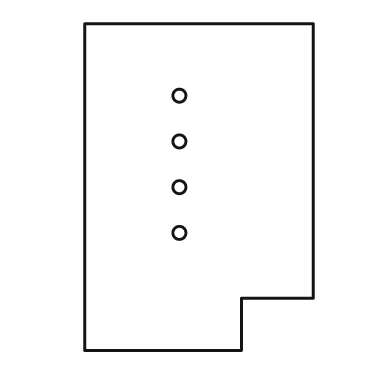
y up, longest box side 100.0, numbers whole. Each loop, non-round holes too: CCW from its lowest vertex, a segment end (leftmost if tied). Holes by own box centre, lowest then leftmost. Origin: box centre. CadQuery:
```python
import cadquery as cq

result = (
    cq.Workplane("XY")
    .moveTo(-35.0, -50.0)
    .lineTo(13.0, -50.0)
    .lineTo(13.0, -34.0)
    .lineTo(35.0, -34.0)
    .lineTo(35.0, 50.0)
    .lineTo(-35.0, 50.0)
    .close()
    .moveTo(-6.0, -14.0)
    .circle(2.0)
    .moveTo(-6.0, 0.0)
    .circle(2.0)
    .moveTo(-6.0, 14.0)
    .circle(2.0)
    .moveTo(-6.0, 28.0)
    .circle(2.0)
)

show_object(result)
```